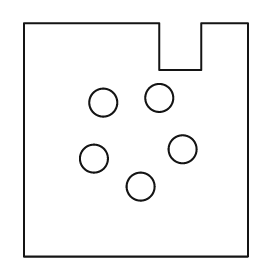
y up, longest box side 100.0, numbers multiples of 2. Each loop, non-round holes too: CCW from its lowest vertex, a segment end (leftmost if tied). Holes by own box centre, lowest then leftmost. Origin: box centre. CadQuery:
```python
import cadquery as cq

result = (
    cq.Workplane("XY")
    .moveTo(-48.0, -50.0)
    .lineTo(48.0, -50.0)
    .lineTo(48.0, 50.0)
    .lineTo(28.0, 50.0)
    .lineTo(28.0, 30.0)
    .lineTo(10.0, 30.0)
    .lineTo(10.0, 50.0)
    .lineTo(-48.0, 50.0)
    .close()
    .moveTo(2.0, -20.0)
    .circle(6.0)
    .moveTo(-18.0, -8.0)
    .circle(6.0)
    .moveTo(20.0, -4.0)
    .circle(6.0)
    .moveTo(-14.0, 16.0)
    .circle(6.0)
    .moveTo(10.0, 18.0)
    .circle(6.0)
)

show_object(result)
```